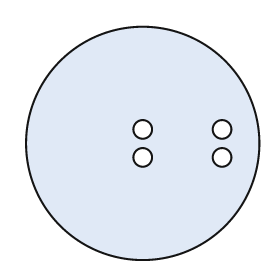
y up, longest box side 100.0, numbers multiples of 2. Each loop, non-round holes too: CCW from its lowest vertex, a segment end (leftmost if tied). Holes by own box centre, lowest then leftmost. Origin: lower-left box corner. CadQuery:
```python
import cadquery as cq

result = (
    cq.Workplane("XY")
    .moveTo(50.0, 50.0)
    .circle(50.0)
    .moveTo(50.0, 44.0)
    .circle(4.0)
    .moveTo(84.0, 44.0)
    .circle(4.0)
    .moveTo(50.0, 56.0)
    .circle(4.0)
    .moveTo(84.0, 56.0)
    .circle(4.0)
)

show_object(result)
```